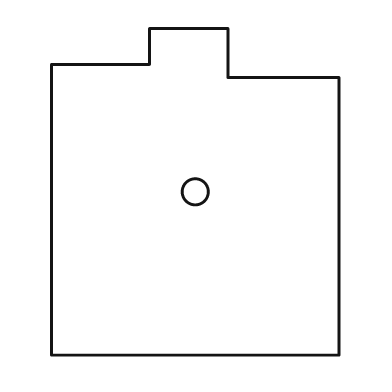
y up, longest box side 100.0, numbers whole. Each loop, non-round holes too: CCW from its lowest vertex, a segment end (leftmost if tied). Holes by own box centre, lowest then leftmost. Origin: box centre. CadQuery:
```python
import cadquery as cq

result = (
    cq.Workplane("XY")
    .moveTo(-44.0, -50.0)
    .lineTo(44.0, -50.0)
    .lineTo(44.0, 35.0)
    .lineTo(10.0, 35.0)
    .lineTo(10.0, 50.0)
    .lineTo(-14.0, 50.0)
    .lineTo(-14.0, 39.0)
    .lineTo(-44.0, 39.0)
    .close()
    .moveTo(0.0, 0.0)
    .circle(4.0)
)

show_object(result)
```